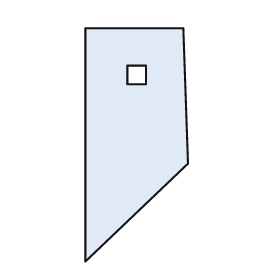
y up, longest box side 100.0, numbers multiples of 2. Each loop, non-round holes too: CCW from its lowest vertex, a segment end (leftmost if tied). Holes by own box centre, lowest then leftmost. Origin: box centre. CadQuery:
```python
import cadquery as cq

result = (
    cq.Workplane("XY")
    .moveTo(-22.0, -50.0)
    .lineTo(22.0, -8.0)
    .lineTo(20.0, 50.0)
    .lineTo(-22.0, 50.0)
    .close()
    .moveTo(-4.0, 26.0)
    .lineTo(4.0, 26.0)
    .lineTo(4.0, 34.0)
    .lineTo(-4.0, 34.0)
    .close()
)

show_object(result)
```